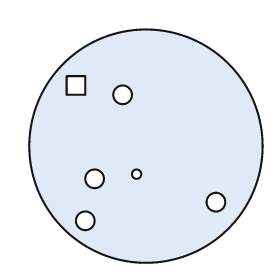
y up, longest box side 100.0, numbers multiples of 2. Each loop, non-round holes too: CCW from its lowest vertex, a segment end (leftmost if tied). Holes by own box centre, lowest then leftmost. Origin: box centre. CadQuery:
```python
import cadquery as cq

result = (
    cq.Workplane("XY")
    .moveTo(0.0, 0.0)
    .circle(50.0)
    .moveTo(-26.0, -32.0)
    .circle(4.0)
    .moveTo(30.0, -24.0)
    .circle(4.0)
    .moveTo(-22.0, -14.0)
    .circle(4.0)
    .moveTo(-4.0, -12.0)
    .circle(2.0)
    .moveTo(-10.0, 22.0)
    .circle(4.0)
    .moveTo(-34.0, 22.0)
    .lineTo(-26.0, 22.0)
    .lineTo(-26.0, 30.0)
    .lineTo(-34.0, 30.0)
    .close()
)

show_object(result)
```